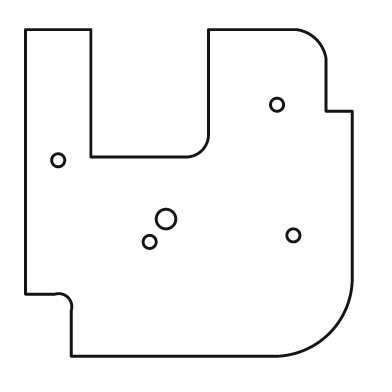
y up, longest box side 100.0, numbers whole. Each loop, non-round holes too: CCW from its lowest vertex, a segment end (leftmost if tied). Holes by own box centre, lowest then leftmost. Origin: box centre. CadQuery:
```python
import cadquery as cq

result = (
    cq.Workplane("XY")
    .moveTo(-36.0, -50.0)
    .lineTo(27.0, -50.0)
    .threePointArc((43.0, -43.0), (50.0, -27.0))
    .lineTo(50.0, 25.0)
    .lineTo(42.0, 25.0)
    .lineTo(42.0, 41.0)
    .threePointArc((39.0, 47.0), (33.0, 50.0))
    .lineTo(6.0, 50.0)
    .lineTo(6.0, 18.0)
    .threePointArc((4.0, 13.0), (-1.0, 11.0))
    .lineTo(-30.0, 11.0)
    .lineTo(-30.0, 50.0)
    .lineTo(-50.0, 50.0)
    .lineTo(-50.0, -31.0)
    .lineTo(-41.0, -31.0)
    .threePointArc((-37.0, -32.0), (-36.0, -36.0))
    .close()
    .moveTo(-12.0, -15.0)
    .circle(2.0)
    .moveTo(32.0, -13.0)
    .circle(2.0)
    .moveTo(-7.0, -8.0)
    .circle(3.0)
    .moveTo(-40.0, 10.0)
    .circle(2.0)
    .moveTo(27.0, 27.0)
    .circle(2.0)
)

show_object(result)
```